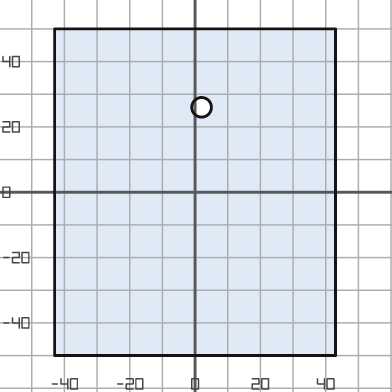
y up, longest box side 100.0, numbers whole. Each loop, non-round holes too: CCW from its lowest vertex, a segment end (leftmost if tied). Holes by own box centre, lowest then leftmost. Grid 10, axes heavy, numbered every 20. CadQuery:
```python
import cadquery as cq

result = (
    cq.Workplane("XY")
    .moveTo(-43.0, -50.0)
    .lineTo(43.0, -50.0)
    .lineTo(43.0, 50.0)
    .lineTo(-43.0, 50.0)
    .close()
    .moveTo(2.0, 26.0)
    .circle(3.0)
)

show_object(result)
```